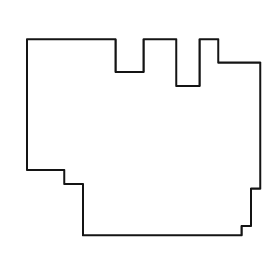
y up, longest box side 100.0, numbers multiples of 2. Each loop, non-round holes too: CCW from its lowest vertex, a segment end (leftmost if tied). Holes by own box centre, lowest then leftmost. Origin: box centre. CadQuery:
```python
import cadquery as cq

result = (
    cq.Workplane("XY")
    .moveTo(-26.0, -42.0)
    .lineTo(42.0, -42.0)
    .lineTo(42.0, -38.0)
    .lineTo(46.0, -38.0)
    .lineTo(46.0, -22.0)
    .lineTo(50.0, -22.0)
    .lineTo(50.0, 32.0)
    .lineTo(32.0, 32.0)
    .lineTo(32.0, 42.0)
    .lineTo(24.0, 42.0)
    .lineTo(24.0, 22.0)
    .lineTo(14.0, 22.0)
    .lineTo(14.0, 42.0)
    .lineTo(0.0, 42.0)
    .lineTo(0.0, 28.0)
    .lineTo(-12.0, 28.0)
    .lineTo(-12.0, 42.0)
    .lineTo(-50.0, 42.0)
    .lineTo(-50.0, -14.0)
    .lineTo(-34.0, -14.0)
    .lineTo(-34.0, -20.0)
    .lineTo(-26.0, -20.0)
    .close()
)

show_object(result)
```